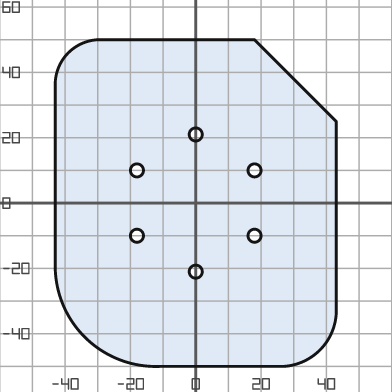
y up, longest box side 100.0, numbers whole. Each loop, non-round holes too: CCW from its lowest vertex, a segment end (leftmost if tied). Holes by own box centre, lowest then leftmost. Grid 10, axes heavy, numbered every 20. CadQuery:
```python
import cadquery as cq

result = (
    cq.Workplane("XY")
    .moveTo(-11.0, -50.0)
    .lineTo(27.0, -50.0)
    .threePointArc((38.0, -45.0), (43.0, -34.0))
    .lineTo(43.0, 25.0)
    .lineTo(18.0, 50.0)
    .lineTo(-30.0, 50.0)
    .threePointArc((-39.0, 46.0), (-43.0, 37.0))
    .lineTo(-43.0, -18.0)
    .threePointArc((-34.0, -41.0), (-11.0, -50.0))
    .close()
    .moveTo(0.0, -21.0)
    .circle(2.0)
    .moveTo(-18.0, -10.0)
    .circle(2.0)
    .moveTo(18.0, -10.0)
    .circle(2.0)
    .moveTo(-18.0, 10.0)
    .circle(2.0)
    .moveTo(18.0, 10.0)
    .circle(2.0)
    .moveTo(0.0, 21.0)
    .circle(2.0)
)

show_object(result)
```